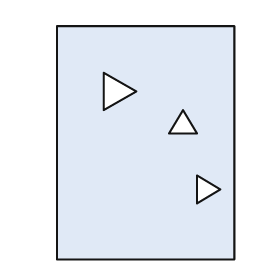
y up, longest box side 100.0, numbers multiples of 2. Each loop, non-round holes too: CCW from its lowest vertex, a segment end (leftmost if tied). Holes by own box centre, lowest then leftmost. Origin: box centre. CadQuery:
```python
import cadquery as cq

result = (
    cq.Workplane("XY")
    .moveTo(-38.0, -50.0)
    .lineTo(38.0, -50.0)
    .lineTo(38.0, 50.0)
    .lineTo(-38.0, 50.0)
    .close()
    .moveTo(22.0, -26.0)
    .lineTo(32.0, -20.0)
    .lineTo(22.0, -14.0)
    .close()
    .moveTo(10.0, 4.0)
    .lineTo(22.0, 4.0)
    .lineTo(16.0, 14.0)
    .close()
    .moveTo(-18.0, 14.0)
    .lineTo(-4.0, 22.0)
    .lineTo(-18.0, 30.0)
    .close()
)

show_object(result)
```